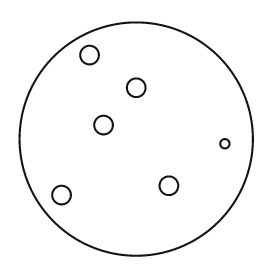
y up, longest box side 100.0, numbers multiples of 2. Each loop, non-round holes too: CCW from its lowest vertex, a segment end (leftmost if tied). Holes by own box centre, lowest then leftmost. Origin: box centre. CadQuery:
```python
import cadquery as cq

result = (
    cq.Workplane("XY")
    .moveTo(0.0, 0.0)
    .circle(50.0)
    .moveTo(-32.0, -24.0)
    .circle(4.0)
    .moveTo(14.0, -20.0)
    .circle(4.0)
    .moveTo(38.0, -2.0)
    .circle(2.0)
    .moveTo(-14.0, 6.0)
    .circle(4.0)
    .moveTo(0.0, 22.0)
    .circle(4.0)
    .moveTo(-20.0, 36.0)
    .circle(4.0)
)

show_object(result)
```